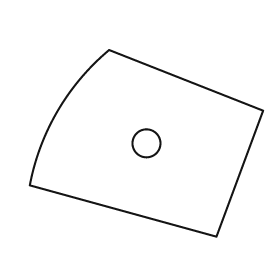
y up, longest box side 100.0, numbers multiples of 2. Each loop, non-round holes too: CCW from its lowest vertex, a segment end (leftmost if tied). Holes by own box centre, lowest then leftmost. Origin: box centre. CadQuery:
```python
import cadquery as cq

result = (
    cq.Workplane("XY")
    .moveTo(30.0, -40.0)
    .lineTo(50.0, 14.0)
    .lineTo(-16.0, 40.0)
    .threePointArc((-38.0, 14.0), (-50.0, -18.0))
    .close()
    .moveTo(0.0, 0.0)
    .circle(6.0)
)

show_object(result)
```